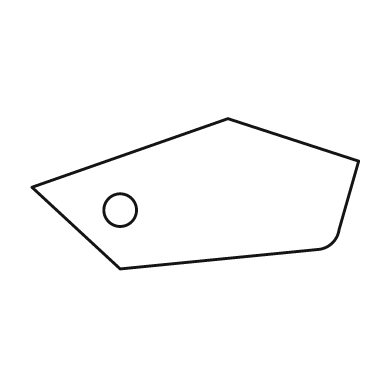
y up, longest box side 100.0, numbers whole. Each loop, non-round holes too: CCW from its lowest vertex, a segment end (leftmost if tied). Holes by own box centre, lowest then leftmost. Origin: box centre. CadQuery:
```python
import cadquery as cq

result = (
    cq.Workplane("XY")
    .moveTo(-23.0, -23.0)
    .lineTo(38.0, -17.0)
    .threePointArc((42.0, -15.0), (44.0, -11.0))
    .lineTo(50.0, 10.0)
    .lineTo(10.0, 23.0)
    .lineTo(-50.0, 2.0)
    .close()
    .moveTo(-23.0, -5.0)
    .circle(5.0)
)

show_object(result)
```